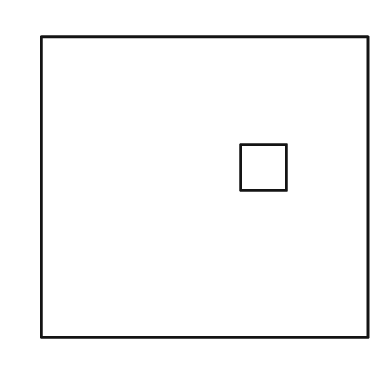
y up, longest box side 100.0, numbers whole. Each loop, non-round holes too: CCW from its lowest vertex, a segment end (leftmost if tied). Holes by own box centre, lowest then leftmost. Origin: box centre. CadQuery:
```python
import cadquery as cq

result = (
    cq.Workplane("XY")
    .moveTo(-50.0, -46.0)
    .lineTo(50.0, -46.0)
    .lineTo(50.0, 46.0)
    .lineTo(-50.0, 46.0)
    .close()
    .moveTo(11.0, -1.0)
    .lineTo(25.0, -1.0)
    .lineTo(25.0, 13.0)
    .lineTo(11.0, 13.0)
    .close()
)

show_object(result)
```